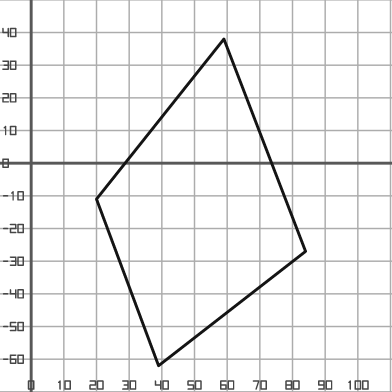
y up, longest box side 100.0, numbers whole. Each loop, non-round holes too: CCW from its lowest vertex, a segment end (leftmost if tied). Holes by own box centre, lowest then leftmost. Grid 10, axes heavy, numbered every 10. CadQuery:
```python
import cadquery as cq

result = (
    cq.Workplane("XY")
    .moveTo(39.0, -62.0)
    .lineTo(84.0, -27.0)
    .lineTo(59.0, 38.0)
    .lineTo(20.0, -11.0)
    .close()
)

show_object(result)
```